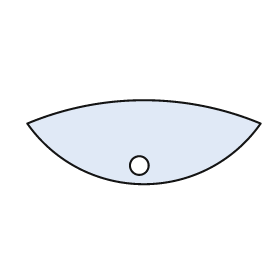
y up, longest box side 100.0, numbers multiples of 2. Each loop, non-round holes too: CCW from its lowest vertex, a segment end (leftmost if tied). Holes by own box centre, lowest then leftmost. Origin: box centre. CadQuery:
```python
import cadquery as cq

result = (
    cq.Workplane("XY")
    .moveTo(-50.0, 8.0)
    .threePointArc((0.0, -18.0), (50.0, 8.0))
    .threePointArc((0.0, 18.0), (-50.0, 8.0))
    .close()
    .moveTo(-2.0, -10.0)
    .circle(4.0)
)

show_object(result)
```